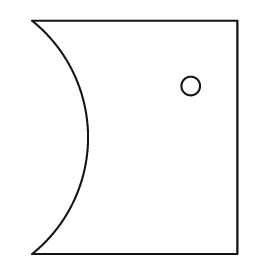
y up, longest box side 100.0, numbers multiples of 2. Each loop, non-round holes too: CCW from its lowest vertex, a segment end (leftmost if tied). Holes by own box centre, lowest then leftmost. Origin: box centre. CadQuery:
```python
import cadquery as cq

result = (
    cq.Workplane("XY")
    .moveTo(-44.0, -50.0)
    .lineTo(44.0, -50.0)
    .lineTo(44.0, 50.0)
    .lineTo(-44.0, 50.0)
    .threePointArc((-20.0, 0.0), (-44.0, -50.0))
    .close()
    .moveTo(24.0, 22.0)
    .circle(4.0)
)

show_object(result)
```